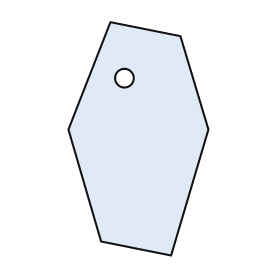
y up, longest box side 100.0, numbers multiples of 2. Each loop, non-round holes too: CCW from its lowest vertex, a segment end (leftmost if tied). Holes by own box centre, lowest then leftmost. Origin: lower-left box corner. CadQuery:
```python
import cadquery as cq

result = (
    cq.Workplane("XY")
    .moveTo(44.0, 0.0)
    .lineTo(60.0, 54.0)
    .lineTo(48.0, 94.0)
    .lineTo(18.0, 100.0)
    .lineTo(0.0, 54.0)
    .lineTo(14.0, 6.0)
    .close()
    .moveTo(24.0, 76.0)
    .circle(4.0)
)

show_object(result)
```